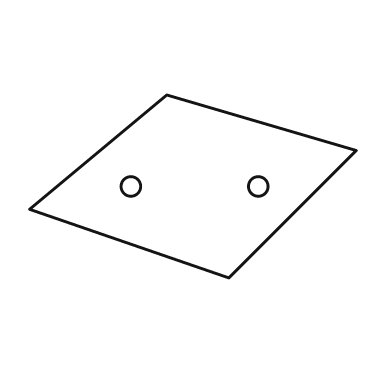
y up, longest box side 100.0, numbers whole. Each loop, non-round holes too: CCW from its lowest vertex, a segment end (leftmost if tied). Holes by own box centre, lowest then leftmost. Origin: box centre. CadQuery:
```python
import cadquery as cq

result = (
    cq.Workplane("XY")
    .moveTo(11.0, -28.0)
    .lineTo(50.0, 11.0)
    .lineTo(-8.0, 28.0)
    .lineTo(-50.0, -7.0)
    .close()
    .moveTo(-19.0, 0.0)
    .circle(3.0)
    .moveTo(20.0, 0.0)
    .circle(3.0)
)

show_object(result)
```